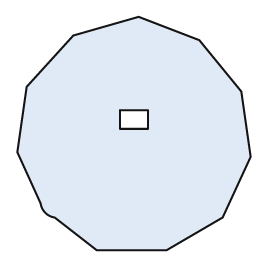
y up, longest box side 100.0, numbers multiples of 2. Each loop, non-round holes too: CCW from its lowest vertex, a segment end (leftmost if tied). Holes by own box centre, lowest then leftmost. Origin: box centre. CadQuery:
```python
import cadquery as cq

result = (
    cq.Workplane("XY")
    .moveTo(-16.0, -50.0)
    .lineTo(14.0, -50.0)
    .lineTo(38.0, -36.0)
    .lineTo(50.0, -10.0)
    .lineTo(46.0, 18.0)
    .lineTo(28.0, 40.0)
    .lineTo(2.0, 50.0)
    .lineTo(-26.0, 42.0)
    .lineTo(-46.0, 20.0)
    .lineTo(-50.0, -8.0)
    .lineTo(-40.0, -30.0)
    .threePointArc((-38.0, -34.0), (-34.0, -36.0))
    .close()
    .moveTo(-6.0, 2.0)
    .lineTo(6.0, 2.0)
    .lineTo(6.0, 10.0)
    .lineTo(-6.0, 10.0)
    .close()
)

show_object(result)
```